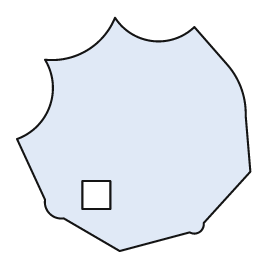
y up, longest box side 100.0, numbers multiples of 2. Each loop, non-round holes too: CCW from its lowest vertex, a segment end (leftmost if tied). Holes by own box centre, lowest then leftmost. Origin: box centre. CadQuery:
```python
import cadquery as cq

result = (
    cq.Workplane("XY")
    .moveTo(-6.0, -50.0)
    .lineTo(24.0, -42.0)
    .threePointArc((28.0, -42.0), (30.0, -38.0))
    .lineTo(50.0, -16.0)
    .lineTo(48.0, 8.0)
    .threePointArc((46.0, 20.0), (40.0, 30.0))
    .lineTo(26.0, 46.0)
    .threePointArc((8.0, 40.0), (-8.0, 50.0))
    .threePointArc((-20.0, 36.0), (-38.0, 32.0))
    .threePointArc((-36.0, 12.0), (-50.0, -2.0))
    .lineTo(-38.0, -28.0)
    .threePointArc((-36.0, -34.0), (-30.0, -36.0))
    .close()
    .moveTo(-22.0, -32.0)
    .lineTo(-10.0, -32.0)
    .lineTo(-10.0, -20.0)
    .lineTo(-22.0, -20.0)
    .close()
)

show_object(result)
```